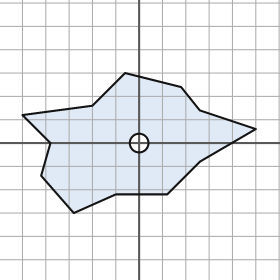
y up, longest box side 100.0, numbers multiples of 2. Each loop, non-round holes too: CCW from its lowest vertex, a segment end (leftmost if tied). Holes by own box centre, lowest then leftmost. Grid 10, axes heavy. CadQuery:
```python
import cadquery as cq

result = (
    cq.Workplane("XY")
    .moveTo(-28.0, -30.0)
    .lineTo(-10.0, -22.0)
    .lineTo(12.0, -22.0)
    .lineTo(26.0, -8.0)
    .lineTo(50.0, 6.0)
    .lineTo(26.0, 14.0)
    .lineTo(18.0, 24.0)
    .lineTo(-6.0, 30.0)
    .lineTo(-20.0, 16.0)
    .lineTo(-50.0, 12.0)
    .lineTo(-38.0, 0.0)
    .lineTo(-42.0, -14.0)
    .close()
    .moveTo(0.0, 0.0)
    .circle(4.0)
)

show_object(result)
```